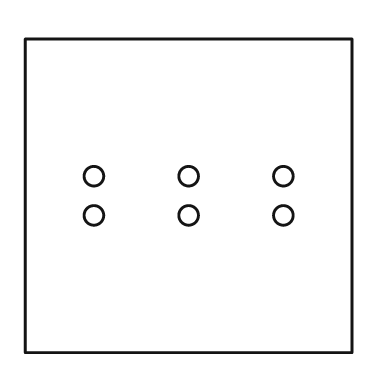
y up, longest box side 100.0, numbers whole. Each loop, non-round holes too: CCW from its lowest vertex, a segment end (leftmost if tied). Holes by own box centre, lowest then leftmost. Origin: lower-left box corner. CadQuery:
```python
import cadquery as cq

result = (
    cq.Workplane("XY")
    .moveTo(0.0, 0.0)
    .lineTo(100.0, 0.0)
    .lineTo(100.0, 96.0)
    .lineTo(0.0, 96.0)
    .close()
    .moveTo(21.0, 42.0)
    .circle(3.0)
    .moveTo(50.0, 42.0)
    .circle(3.0)
    .moveTo(79.0, 42.0)
    .circle(3.0)
    .moveTo(21.0, 54.0)
    .circle(3.0)
    .moveTo(50.0, 54.0)
    .circle(3.0)
    .moveTo(79.0, 54.0)
    .circle(3.0)
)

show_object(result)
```